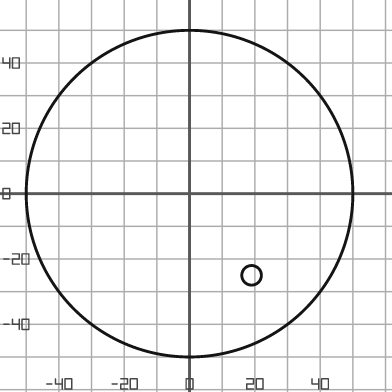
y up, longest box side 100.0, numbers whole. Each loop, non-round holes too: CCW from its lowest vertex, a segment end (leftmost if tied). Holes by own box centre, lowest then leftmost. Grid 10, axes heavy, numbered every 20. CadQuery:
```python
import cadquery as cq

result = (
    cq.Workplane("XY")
    .moveTo(0.0, 0.0)
    .circle(50.0)
    .moveTo(19.0, -25.0)
    .circle(3.0)
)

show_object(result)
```